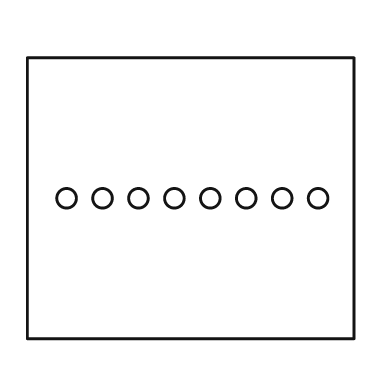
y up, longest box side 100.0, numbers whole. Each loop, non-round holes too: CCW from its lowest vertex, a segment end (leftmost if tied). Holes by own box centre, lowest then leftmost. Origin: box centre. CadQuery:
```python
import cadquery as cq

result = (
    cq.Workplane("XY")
    .moveTo(-50.0, -43.0)
    .lineTo(50.0, -43.0)
    .lineTo(50.0, 43.0)
    .lineTo(-50.0, 43.0)
    .close()
    .moveTo(-38.0, 0.0)
    .circle(3.0)
    .moveTo(-27.0, 0.0)
    .circle(3.0)
    .moveTo(-16.0, 0.0)
    .circle(3.0)
    .moveTo(-5.0, 0.0)
    .circle(3.0)
    .moveTo(6.0, 0.0)
    .circle(3.0)
    .moveTo(17.0, 0.0)
    .circle(3.0)
    .moveTo(28.0, 0.0)
    .circle(3.0)
    .moveTo(39.0, 0.0)
    .circle(3.0)
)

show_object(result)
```